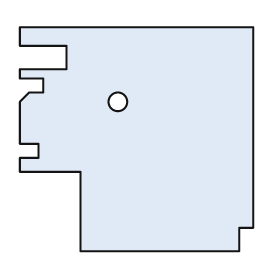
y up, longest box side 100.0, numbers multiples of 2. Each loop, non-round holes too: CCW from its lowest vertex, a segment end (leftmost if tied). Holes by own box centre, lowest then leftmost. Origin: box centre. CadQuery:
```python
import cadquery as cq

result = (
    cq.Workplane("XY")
    .moveTo(-24.0, -48.0)
    .lineTo(44.0, -48.0)
    .lineTo(44.0, -38.0)
    .lineTo(50.0, -38.0)
    .lineTo(50.0, 48.0)
    .lineTo(-50.0, 48.0)
    .lineTo(-50.0, 40.0)
    .lineTo(-30.0, 40.0)
    .lineTo(-30.0, 30.0)
    .lineTo(-50.0, 30.0)
    .lineTo(-50.0, 26.0)
    .lineTo(-40.0, 26.0)
    .lineTo(-40.0, 20.0)
    .lineTo(-46.0, 20.0)
    .lineTo(-50.0, 16.0)
    .lineTo(-50.0, -2.0)
    .lineTo(-42.0, -2.0)
    .lineTo(-42.0, -8.0)
    .lineTo(-50.0, -8.0)
    .lineTo(-50.0, -14.0)
    .lineTo(-24.0, -14.0)
    .close()
    .moveTo(-8.0, 16.0)
    .circle(4.0)
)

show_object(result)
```